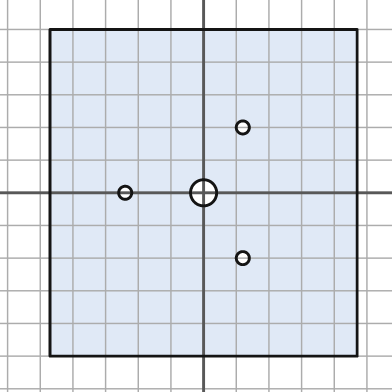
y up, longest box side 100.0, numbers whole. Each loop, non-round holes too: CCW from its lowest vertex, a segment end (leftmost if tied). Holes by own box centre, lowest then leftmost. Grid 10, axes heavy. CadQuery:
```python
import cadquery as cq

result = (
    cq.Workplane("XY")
    .moveTo(-47.0, -50.0)
    .lineTo(47.0, -50.0)
    .lineTo(47.0, 50.0)
    .lineTo(-47.0, 50.0)
    .close()
    .moveTo(12.0, -20.0)
    .circle(2.0)
    .moveTo(-24.0, 0.0)
    .circle(2.0)
    .moveTo(0.0, 0.0)
    .circle(4.0)
    .moveTo(12.0, 20.0)
    .circle(2.0)
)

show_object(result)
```